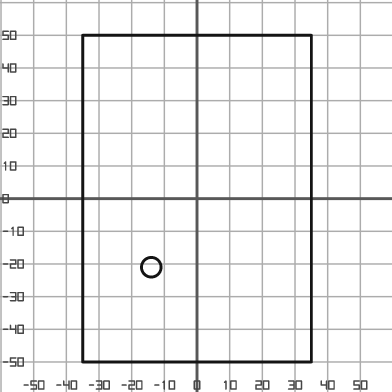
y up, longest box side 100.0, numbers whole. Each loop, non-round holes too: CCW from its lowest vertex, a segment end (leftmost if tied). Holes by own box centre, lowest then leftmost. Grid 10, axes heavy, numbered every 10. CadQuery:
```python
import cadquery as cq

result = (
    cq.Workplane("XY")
    .moveTo(-35.0, -50.0)
    .lineTo(35.0, -50.0)
    .lineTo(35.0, 50.0)
    .lineTo(-35.0, 50.0)
    .close()
    .moveTo(-14.0, -21.0)
    .circle(3.0)
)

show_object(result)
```